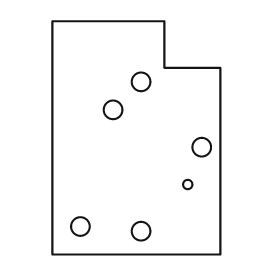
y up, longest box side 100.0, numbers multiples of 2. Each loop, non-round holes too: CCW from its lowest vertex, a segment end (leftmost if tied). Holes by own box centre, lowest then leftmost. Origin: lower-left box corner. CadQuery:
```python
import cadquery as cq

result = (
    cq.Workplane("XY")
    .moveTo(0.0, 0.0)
    .lineTo(72.0, 0.0)
    .lineTo(72.0, 80.0)
    .lineTo(48.0, 80.0)
    .lineTo(48.0, 100.0)
    .lineTo(0.0, 100.0)
    .close()
    .moveTo(38.0, 10.0)
    .circle(4.0)
    .moveTo(12.0, 12.0)
    .circle(4.0)
    .moveTo(58.0, 30.0)
    .circle(2.0)
    .moveTo(64.0, 46.0)
    .circle(4.0)
    .moveTo(26.0, 62.0)
    .circle(4.0)
    .moveTo(38.0, 74.0)
    .circle(4.0)
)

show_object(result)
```